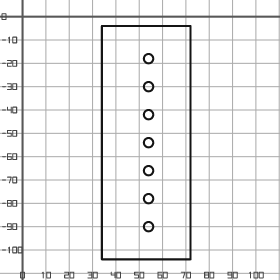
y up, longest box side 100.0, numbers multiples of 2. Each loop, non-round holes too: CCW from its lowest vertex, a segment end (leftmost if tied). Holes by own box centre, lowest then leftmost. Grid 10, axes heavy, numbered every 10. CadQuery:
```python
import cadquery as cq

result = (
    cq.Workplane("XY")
    .moveTo(34.0, -104.0)
    .lineTo(72.0, -104.0)
    .lineTo(72.0, -4.0)
    .lineTo(34.0, -4.0)
    .close()
    .moveTo(54.0, -90.0)
    .circle(2.0)
    .moveTo(54.0, -78.0)
    .circle(2.0)
    .moveTo(54.0, -66.0)
    .circle(2.0)
    .moveTo(54.0, -54.0)
    .circle(2.0)
    .moveTo(54.0, -42.0)
    .circle(2.0)
    .moveTo(54.0, -30.0)
    .circle(2.0)
    .moveTo(54.0, -18.0)
    .circle(2.0)
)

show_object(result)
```